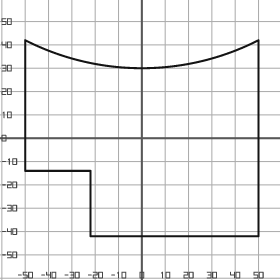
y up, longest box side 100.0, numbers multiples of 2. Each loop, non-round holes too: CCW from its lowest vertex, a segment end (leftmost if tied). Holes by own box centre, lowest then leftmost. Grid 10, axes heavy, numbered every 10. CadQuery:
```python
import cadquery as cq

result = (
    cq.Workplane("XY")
    .moveTo(-22.0, -42.0)
    .lineTo(50.0, -42.0)
    .lineTo(50.0, 42.0)
    .threePointArc((0.0, 30.0), (-50.0, 42.0))
    .lineTo(-50.0, -14.0)
    .lineTo(-22.0, -14.0)
    .close()
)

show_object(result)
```